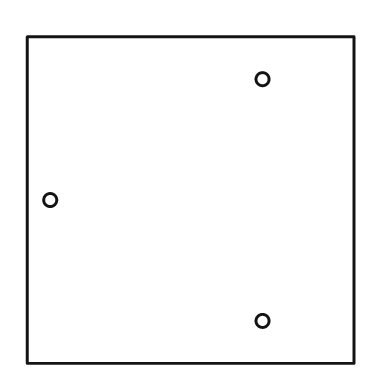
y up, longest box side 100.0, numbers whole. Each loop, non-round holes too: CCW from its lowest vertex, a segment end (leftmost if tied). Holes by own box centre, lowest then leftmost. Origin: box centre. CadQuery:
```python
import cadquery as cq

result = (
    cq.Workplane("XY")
    .moveTo(-50.0, -50.0)
    .lineTo(50.0, -50.0)
    .lineTo(50.0, 50.0)
    .lineTo(-50.0, 50.0)
    .close()
    .moveTo(22.0, -37.0)
    .circle(2.0)
    .moveTo(-43.0, 0.0)
    .circle(2.0)
    .moveTo(22.0, 37.0)
    .circle(2.0)
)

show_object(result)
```